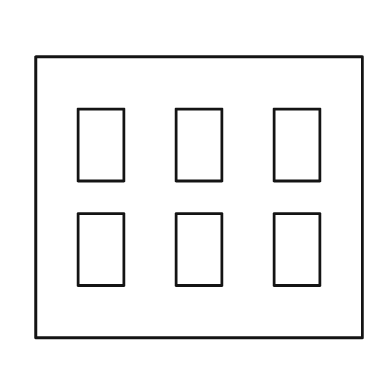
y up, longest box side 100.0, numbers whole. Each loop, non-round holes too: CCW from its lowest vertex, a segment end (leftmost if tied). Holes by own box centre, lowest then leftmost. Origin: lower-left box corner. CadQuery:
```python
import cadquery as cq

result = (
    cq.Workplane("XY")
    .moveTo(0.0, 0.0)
    .lineTo(100.0, 0.0)
    .lineTo(100.0, 86.0)
    .lineTo(0.0, 86.0)
    .close()
    .moveTo(13.0, 16.0)
    .lineTo(27.0, 16.0)
    .lineTo(27.0, 38.0)
    .lineTo(13.0, 38.0)
    .close()
    .moveTo(43.0, 16.0)
    .lineTo(57.0, 16.0)
    .lineTo(57.0, 38.0)
    .lineTo(43.0, 38.0)
    .close()
    .moveTo(73.0, 16.0)
    .lineTo(87.0, 16.0)
    .lineTo(87.0, 38.0)
    .lineTo(73.0, 38.0)
    .close()
    .moveTo(13.0, 48.0)
    .lineTo(27.0, 48.0)
    .lineTo(27.0, 70.0)
    .lineTo(13.0, 70.0)
    .close()
    .moveTo(43.0, 48.0)
    .lineTo(57.0, 48.0)
    .lineTo(57.0, 70.0)
    .lineTo(43.0, 70.0)
    .close()
    .moveTo(73.0, 48.0)
    .lineTo(87.0, 48.0)
    .lineTo(87.0, 70.0)
    .lineTo(73.0, 70.0)
    .close()
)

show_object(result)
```